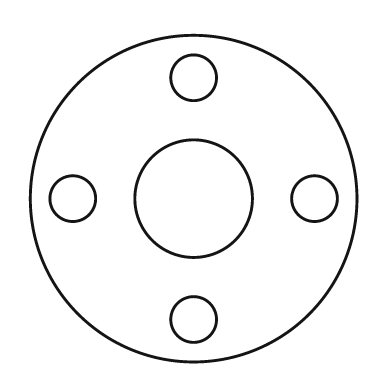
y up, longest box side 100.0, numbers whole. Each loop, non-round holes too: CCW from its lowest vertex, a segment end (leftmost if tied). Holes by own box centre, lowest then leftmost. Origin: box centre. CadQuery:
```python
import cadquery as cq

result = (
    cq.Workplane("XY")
    .moveTo(0.0, 0.0)
    .circle(50.0)
    .moveTo(0.0, -37.0)
    .circle(7.0)
    .moveTo(-37.0, 0.0)
    .circle(7.0)
    .moveTo(0.0, 0.0)
    .circle(18.0)
    .moveTo(37.0, 0.0)
    .circle(7.0)
    .moveTo(0.0, 37.0)
    .circle(7.0)
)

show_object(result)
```